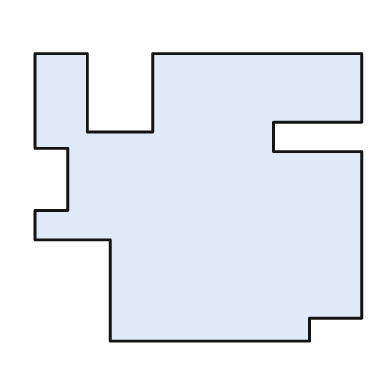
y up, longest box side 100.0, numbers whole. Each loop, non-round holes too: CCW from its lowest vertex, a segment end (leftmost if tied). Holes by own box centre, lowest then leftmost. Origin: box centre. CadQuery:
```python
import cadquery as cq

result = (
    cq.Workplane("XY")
    .moveTo(-27.0, -44.0)
    .lineTo(34.0, -44.0)
    .lineTo(34.0, -37.0)
    .lineTo(50.0, -37.0)
    .lineTo(50.0, 14.0)
    .lineTo(23.0, 14.0)
    .lineTo(23.0, 23.0)
    .lineTo(50.0, 23.0)
    .lineTo(50.0, 44.0)
    .lineTo(-14.0, 44.0)
    .lineTo(-14.0, 20.0)
    .lineTo(-34.0, 20.0)
    .lineTo(-34.0, 44.0)
    .lineTo(-50.0, 44.0)
    .lineTo(-50.0, 15.0)
    .lineTo(-40.0, 15.0)
    .lineTo(-40.0, -4.0)
    .lineTo(-50.0, -4.0)
    .lineTo(-50.0, -13.0)
    .lineTo(-27.0, -13.0)
    .close()
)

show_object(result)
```